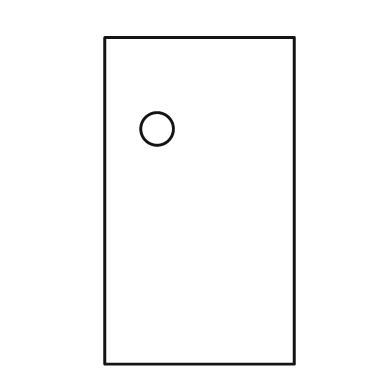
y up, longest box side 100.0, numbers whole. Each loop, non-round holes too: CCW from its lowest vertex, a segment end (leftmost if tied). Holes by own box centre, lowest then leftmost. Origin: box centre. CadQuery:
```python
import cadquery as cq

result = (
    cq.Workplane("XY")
    .moveTo(-29.0, -50.0)
    .lineTo(29.0, -50.0)
    .lineTo(29.0, 50.0)
    .lineTo(-29.0, 50.0)
    .close()
    .moveTo(-13.0, 22.0)
    .circle(5.0)
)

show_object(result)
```